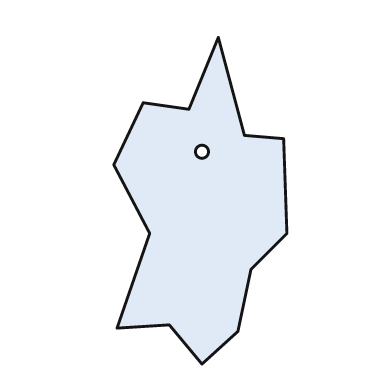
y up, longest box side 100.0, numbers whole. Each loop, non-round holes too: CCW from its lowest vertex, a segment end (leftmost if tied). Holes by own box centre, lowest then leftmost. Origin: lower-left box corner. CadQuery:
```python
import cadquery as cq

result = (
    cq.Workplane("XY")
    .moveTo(27.0, 0.0)
    .lineTo(38.0, 10.0)
    .lineTo(42.0, 29.0)
    .lineTo(53.0, 40.0)
    .lineTo(52.0, 69.0)
    .lineTo(40.0, 70.0)
    .lineTo(32.0, 100.0)
    .lineTo(23.0, 78.0)
    .lineTo(9.0, 80.0)
    .lineTo(0.0, 61.0)
    .lineTo(11.0, 40.0)
    .lineTo(1.0, 11.0)
    .lineTo(17.0, 12.0)
    .close()
    .moveTo(27.0, 65.0)
    .circle(2.0)
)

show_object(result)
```